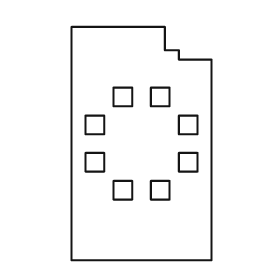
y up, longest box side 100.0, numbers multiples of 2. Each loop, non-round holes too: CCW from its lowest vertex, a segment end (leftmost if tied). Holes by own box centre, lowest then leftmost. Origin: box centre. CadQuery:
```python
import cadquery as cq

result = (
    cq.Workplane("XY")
    .moveTo(-30.0, -50.0)
    .lineTo(30.0, -50.0)
    .lineTo(30.0, 36.0)
    .lineTo(16.0, 36.0)
    .lineTo(16.0, 40.0)
    .lineTo(10.0, 40.0)
    .lineTo(10.0, 50.0)
    .lineTo(-30.0, 50.0)
    .close()
    .moveTo(-12.0, -24.0)
    .lineTo(-4.0, -24.0)
    .lineTo(-4.0, -16.0)
    .lineTo(-12.0, -16.0)
    .close()
    .moveTo(4.0, -24.0)
    .lineTo(12.0, -24.0)
    .lineTo(12.0, -16.0)
    .lineTo(4.0, -16.0)
    .close()
    .moveTo(-24.0, -12.0)
    .lineTo(-16.0, -12.0)
    .lineTo(-16.0, -4.0)
    .lineTo(-24.0, -4.0)
    .close()
    .moveTo(16.0, -12.0)
    .lineTo(24.0, -12.0)
    .lineTo(24.0, -4.0)
    .lineTo(16.0, -4.0)
    .close()
    .moveTo(-24.0, 4.0)
    .lineTo(-16.0, 4.0)
    .lineTo(-16.0, 12.0)
    .lineTo(-24.0, 12.0)
    .close()
    .moveTo(16.0, 4.0)
    .lineTo(24.0, 4.0)
    .lineTo(24.0, 12.0)
    .lineTo(16.0, 12.0)
    .close()
    .moveTo(-12.0, 16.0)
    .lineTo(-4.0, 16.0)
    .lineTo(-4.0, 24.0)
    .lineTo(-12.0, 24.0)
    .close()
    .moveTo(4.0, 16.0)
    .lineTo(12.0, 16.0)
    .lineTo(12.0, 24.0)
    .lineTo(4.0, 24.0)
    .close()
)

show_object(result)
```